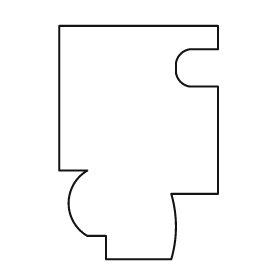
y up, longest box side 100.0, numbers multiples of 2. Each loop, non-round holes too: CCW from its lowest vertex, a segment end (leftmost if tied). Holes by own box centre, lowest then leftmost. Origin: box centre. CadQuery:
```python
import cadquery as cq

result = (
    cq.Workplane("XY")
    .moveTo(-14.0, -50.0)
    .lineTo(14.0, -50.0)
    .threePointArc((16.0, -36.0), (14.0, -22.0))
    .lineTo(34.0, -22.0)
    .lineTo(34.0, 24.0)
    .lineTo(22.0, 24.0)
    .threePointArc((18.0, 26.0), (16.0, 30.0))
    .lineTo(16.0, 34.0)
    .threePointArc((18.0, 38.0), (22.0, 40.0))
    .lineTo(34.0, 40.0)
    .lineTo(34.0, 50.0)
    .lineTo(-34.0, 50.0)
    .lineTo(-34.0, -12.0)
    .lineTo(-22.0, -12.0)
    .threePointArc((-30.0, -26.0), (-22.0, -40.0))
    .lineTo(-14.0, -40.0)
    .close()
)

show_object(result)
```